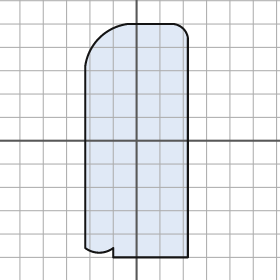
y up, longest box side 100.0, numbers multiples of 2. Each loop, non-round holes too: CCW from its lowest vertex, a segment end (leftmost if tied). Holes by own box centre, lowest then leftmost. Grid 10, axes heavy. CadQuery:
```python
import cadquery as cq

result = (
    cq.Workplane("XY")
    .moveTo(-10.0, -50.0)
    .lineTo(22.0, -50.0)
    .lineTo(22.0, 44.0)
    .threePointArc((20.0, 48.0), (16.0, 50.0))
    .lineTo(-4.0, 50.0)
    .threePointArc((-16.0, 44.0), (-22.0, 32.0))
    .lineTo(-22.0, -46.0)
    .threePointArc((-16.0, -48.0), (-10.0, -46.0))
    .close()
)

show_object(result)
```